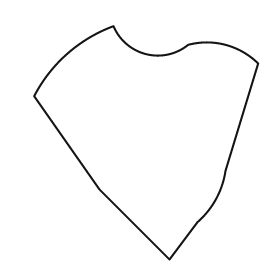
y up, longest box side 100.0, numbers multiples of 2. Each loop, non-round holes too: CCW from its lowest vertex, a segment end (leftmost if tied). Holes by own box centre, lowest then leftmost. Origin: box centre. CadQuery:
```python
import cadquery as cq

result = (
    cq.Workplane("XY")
    .moveTo(10.0, -50.0)
    .lineTo(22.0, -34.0)
    .threePointArc((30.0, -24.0), (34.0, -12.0))
    .lineTo(48.0, 34.0)
    .threePointArc((34.0, 42.0), (18.0, 42.0))
    .threePointArc((0.0, 38.0), (-14.0, 50.0))
    .threePointArc((-34.0, 38.0), (-48.0, 20.0))
    .lineTo(-20.0, -20.0)
    .close()
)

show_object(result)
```